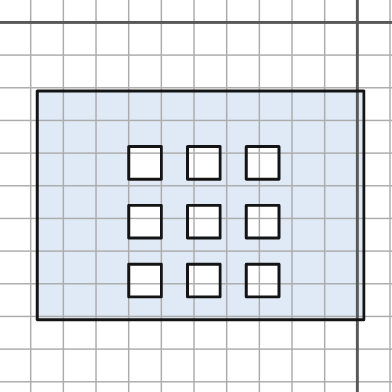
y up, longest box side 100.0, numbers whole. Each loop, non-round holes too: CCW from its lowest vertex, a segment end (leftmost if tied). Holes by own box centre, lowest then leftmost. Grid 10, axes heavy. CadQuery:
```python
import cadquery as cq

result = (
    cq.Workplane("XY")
    .moveTo(-98.0, -91.0)
    .lineTo(2.0, -91.0)
    .lineTo(2.0, -21.0)
    .lineTo(-98.0, -21.0)
    .close()
    .moveTo(-70.0, -84.0)
    .lineTo(-60.0, -84.0)
    .lineTo(-60.0, -74.0)
    .lineTo(-70.0, -74.0)
    .close()
    .moveTo(-52.0, -84.0)
    .lineTo(-42.0, -84.0)
    .lineTo(-42.0, -74.0)
    .lineTo(-52.0, -74.0)
    .close()
    .moveTo(-34.0, -84.0)
    .lineTo(-24.0, -84.0)
    .lineTo(-24.0, -74.0)
    .lineTo(-34.0, -74.0)
    .close()
    .moveTo(-70.0, -66.0)
    .lineTo(-60.0, -66.0)
    .lineTo(-60.0, -56.0)
    .lineTo(-70.0, -56.0)
    .close()
    .moveTo(-52.0, -66.0)
    .lineTo(-42.0, -66.0)
    .lineTo(-42.0, -56.0)
    .lineTo(-52.0, -56.0)
    .close()
    .moveTo(-34.0, -66.0)
    .lineTo(-24.0, -66.0)
    .lineTo(-24.0, -56.0)
    .lineTo(-34.0, -56.0)
    .close()
    .moveTo(-70.0, -48.0)
    .lineTo(-60.0, -48.0)
    .lineTo(-60.0, -38.0)
    .lineTo(-70.0, -38.0)
    .close()
    .moveTo(-52.0, -48.0)
    .lineTo(-42.0, -48.0)
    .lineTo(-42.0, -38.0)
    .lineTo(-52.0, -38.0)
    .close()
    .moveTo(-34.0, -48.0)
    .lineTo(-24.0, -48.0)
    .lineTo(-24.0, -38.0)
    .lineTo(-34.0, -38.0)
    .close()
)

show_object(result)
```